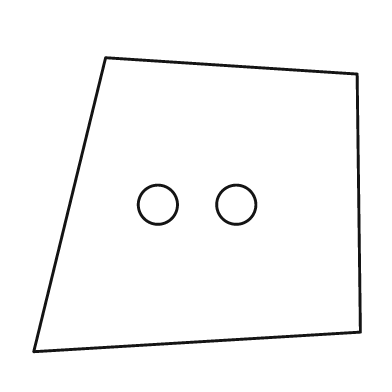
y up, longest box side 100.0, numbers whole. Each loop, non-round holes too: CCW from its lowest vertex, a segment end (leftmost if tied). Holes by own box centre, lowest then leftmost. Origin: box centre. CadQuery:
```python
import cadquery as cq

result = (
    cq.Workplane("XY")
    .moveTo(-50.0, -45.0)
    .lineTo(50.0, -39.0)
    .lineTo(49.0, 40.0)
    .lineTo(-28.0, 45.0)
    .close()
    .moveTo(-12.0, 0.0)
    .circle(6.0)
    .moveTo(12.0, 0.0)
    .circle(6.0)
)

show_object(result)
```